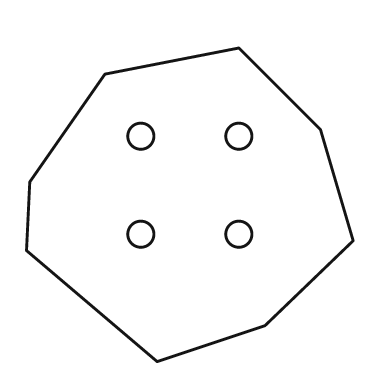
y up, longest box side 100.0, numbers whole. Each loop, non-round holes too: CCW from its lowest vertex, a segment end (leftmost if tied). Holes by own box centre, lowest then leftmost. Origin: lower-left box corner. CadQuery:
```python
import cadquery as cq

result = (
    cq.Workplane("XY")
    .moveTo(40.0, 0.0)
    .lineTo(73.0, 11.0)
    .lineTo(100.0, 37.0)
    .lineTo(90.0, 71.0)
    .lineTo(65.0, 96.0)
    .lineTo(24.0, 88.0)
    .lineTo(1.0, 55.0)
    .lineTo(0.0, 34.0)
    .close()
    .moveTo(35.0, 39.0)
    .circle(4.0)
    .moveTo(65.0, 39.0)
    .circle(4.0)
    .moveTo(35.0, 69.0)
    .circle(4.0)
    .moveTo(65.0, 69.0)
    .circle(4.0)
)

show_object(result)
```